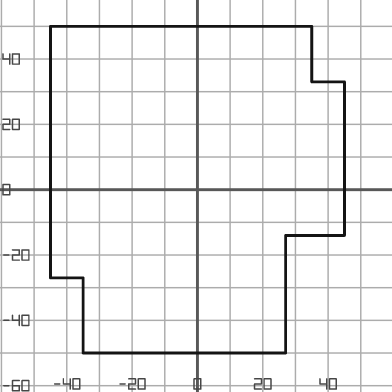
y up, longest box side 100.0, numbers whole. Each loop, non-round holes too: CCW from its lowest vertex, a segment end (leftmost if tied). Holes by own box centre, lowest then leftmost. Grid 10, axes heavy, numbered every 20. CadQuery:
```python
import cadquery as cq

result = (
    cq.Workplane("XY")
    .moveTo(-35.0, -50.0)
    .lineTo(27.0, -50.0)
    .lineTo(27.0, -14.0)
    .lineTo(45.0, -14.0)
    .lineTo(45.0, 33.0)
    .lineTo(35.0, 33.0)
    .lineTo(35.0, 50.0)
    .lineTo(-45.0, 50.0)
    .lineTo(-45.0, -27.0)
    .lineTo(-35.0, -27.0)
    .close()
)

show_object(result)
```